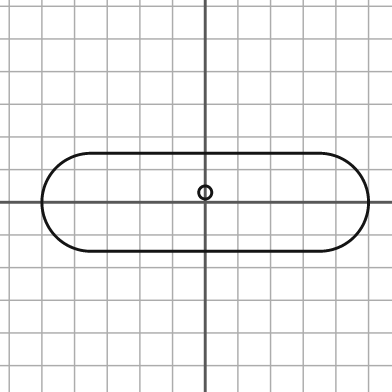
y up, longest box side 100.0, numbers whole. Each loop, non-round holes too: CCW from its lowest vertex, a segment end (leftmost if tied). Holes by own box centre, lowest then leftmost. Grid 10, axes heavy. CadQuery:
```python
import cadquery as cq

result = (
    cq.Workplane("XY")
    .moveTo(-35.0, -15.0)
    .lineTo(35.0, -15.0)
    .threePointArc((50.0, 0.0), (35.0, 15.0))
    .lineTo(-35.0, 15.0)
    .threePointArc((-50.0, 0.0), (-35.0, -15.0))
    .close()
    .moveTo(0.0, 3.0)
    .circle(2.0)
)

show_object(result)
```